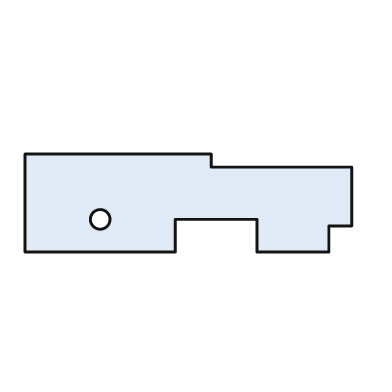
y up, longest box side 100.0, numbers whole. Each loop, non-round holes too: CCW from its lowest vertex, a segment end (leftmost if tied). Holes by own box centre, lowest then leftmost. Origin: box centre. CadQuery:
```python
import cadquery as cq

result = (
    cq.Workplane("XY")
    .moveTo(-50.0, -15.0)
    .lineTo(-4.0, -15.0)
    .lineTo(-4.0, -5.0)
    .lineTo(21.0, -5.0)
    .lineTo(21.0, -15.0)
    .lineTo(43.0, -15.0)
    .lineTo(43.0, -7.0)
    .lineTo(50.0, -7.0)
    .lineTo(50.0, 11.0)
    .lineTo(7.0, 11.0)
    .lineTo(7.0, 15.0)
    .lineTo(-50.0, 15.0)
    .close()
    .moveTo(-27.0, -5.0)
    .circle(3.0)
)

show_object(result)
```